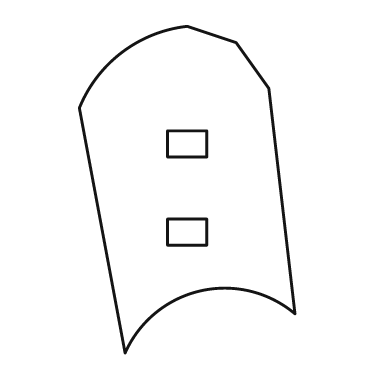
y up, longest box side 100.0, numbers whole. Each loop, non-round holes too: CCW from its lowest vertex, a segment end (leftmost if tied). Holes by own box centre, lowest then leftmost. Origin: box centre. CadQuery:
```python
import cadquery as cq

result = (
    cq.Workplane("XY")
    .moveTo(-19.0, -50.0)
    .threePointArc((4.0, -31.0), (33.0, -38.0))
    .lineTo(25.0, 31.0)
    .lineTo(15.0, 45.0)
    .lineTo(0.0, 50.0)
    .threePointArc((-20.0, 42.0), (-33.0, 25.0))
    .close()
    .moveTo(-6.0, -17.0)
    .lineTo(6.0, -17.0)
    .lineTo(6.0, -9.0)
    .lineTo(-6.0, -9.0)
    .close()
    .moveTo(-6.0, 10.0)
    .lineTo(6.0, 10.0)
    .lineTo(6.0, 18.0)
    .lineTo(-6.0, 18.0)
    .close()
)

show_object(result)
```